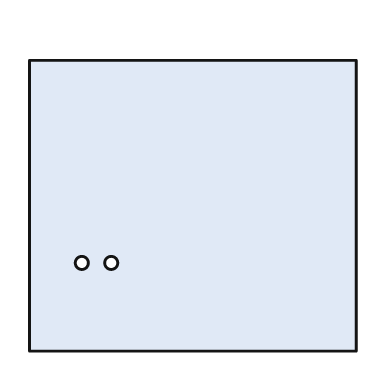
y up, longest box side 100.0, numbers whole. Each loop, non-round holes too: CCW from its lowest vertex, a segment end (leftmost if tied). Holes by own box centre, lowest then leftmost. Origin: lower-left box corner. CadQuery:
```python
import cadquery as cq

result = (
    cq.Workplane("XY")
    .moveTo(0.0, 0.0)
    .lineTo(100.0, 0.0)
    .lineTo(100.0, 89.0)
    .lineTo(0.0, 89.0)
    .close()
    .moveTo(16.0, 27.0)
    .circle(2.0)
    .moveTo(25.0, 27.0)
    .circle(2.0)
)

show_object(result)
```